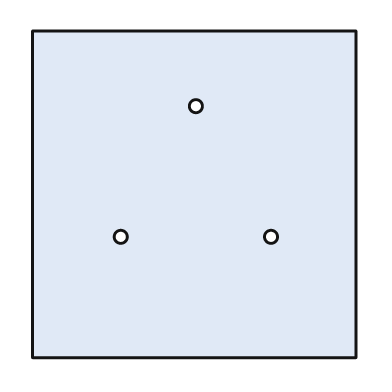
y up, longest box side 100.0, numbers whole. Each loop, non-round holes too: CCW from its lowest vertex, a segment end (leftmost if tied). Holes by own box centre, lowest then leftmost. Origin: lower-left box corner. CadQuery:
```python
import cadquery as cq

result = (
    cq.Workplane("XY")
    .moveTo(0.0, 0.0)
    .lineTo(99.0, 0.0)
    .lineTo(99.0, 100.0)
    .lineTo(0.0, 100.0)
    .close()
    .moveTo(27.0, 37.0)
    .circle(2.0)
    .moveTo(73.0, 37.0)
    .circle(2.0)
    .moveTo(50.0, 77.0)
    .circle(2.0)
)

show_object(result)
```